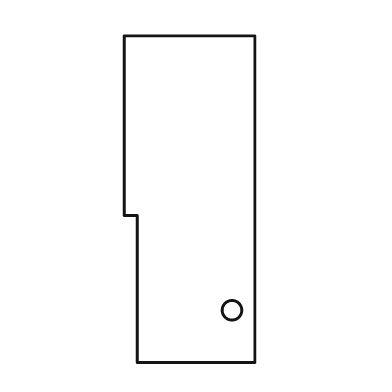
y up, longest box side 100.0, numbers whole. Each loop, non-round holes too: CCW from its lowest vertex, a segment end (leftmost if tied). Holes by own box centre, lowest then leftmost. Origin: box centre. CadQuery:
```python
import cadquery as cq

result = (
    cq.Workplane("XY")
    .moveTo(-16.0, -50.0)
    .lineTo(20.0, -50.0)
    .lineTo(20.0, 50.0)
    .lineTo(-20.0, 50.0)
    .lineTo(-20.0, -5.0)
    .lineTo(-16.0, -5.0)
    .close()
    .moveTo(13.0, -34.0)
    .circle(3.0)
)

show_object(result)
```